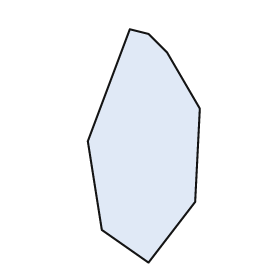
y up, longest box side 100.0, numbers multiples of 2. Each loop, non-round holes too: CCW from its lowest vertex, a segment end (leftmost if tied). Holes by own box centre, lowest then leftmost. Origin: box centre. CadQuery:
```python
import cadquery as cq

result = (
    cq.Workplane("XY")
    .moveTo(2.0, -50.0)
    .lineTo(22.0, -24.0)
    .lineTo(24.0, 16.0)
    .lineTo(10.0, 40.0)
    .lineTo(2.0, 48.0)
    .lineTo(-6.0, 50.0)
    .lineTo(-24.0, 2.0)
    .lineTo(-18.0, -36.0)
    .close()
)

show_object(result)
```